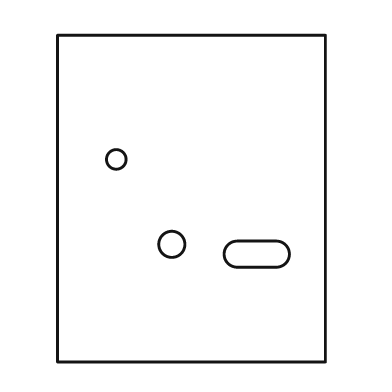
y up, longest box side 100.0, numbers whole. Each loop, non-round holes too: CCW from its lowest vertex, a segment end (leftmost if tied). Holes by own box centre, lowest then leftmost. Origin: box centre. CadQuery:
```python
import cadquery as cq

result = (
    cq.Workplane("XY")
    .moveTo(-41.0, -50.0)
    .lineTo(41.0, -50.0)
    .lineTo(41.0, 50.0)
    .lineTo(-41.0, 50.0)
    .close()
    .moveTo(14.0, -21.0)
    .lineTo(26.0, -21.0)
    .threePointArc((30.0, -17.0), (26.0, -13.0))
    .lineTo(14.0, -13.0)
    .threePointArc((10.0, -17.0), (14.0, -21.0))
    .close()
    .moveTo(-6.0, -14.0)
    .circle(4.0)
    .moveTo(-23.0, 12.0)
    .circle(3.0)
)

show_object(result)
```